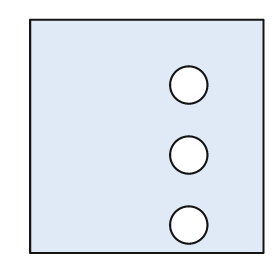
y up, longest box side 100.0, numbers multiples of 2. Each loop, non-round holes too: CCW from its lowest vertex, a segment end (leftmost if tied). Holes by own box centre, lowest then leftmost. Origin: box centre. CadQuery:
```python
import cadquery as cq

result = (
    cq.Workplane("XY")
    .moveTo(-50.0, -50.0)
    .lineTo(50.0, -50.0)
    .lineTo(50.0, 50.0)
    .lineTo(-50.0, 50.0)
    .close()
    .moveTo(18.0, -38.0)
    .circle(8.0)
    .moveTo(18.0, -8.0)
    .circle(8.0)
    .moveTo(18.0, 22.0)
    .circle(8.0)
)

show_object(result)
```